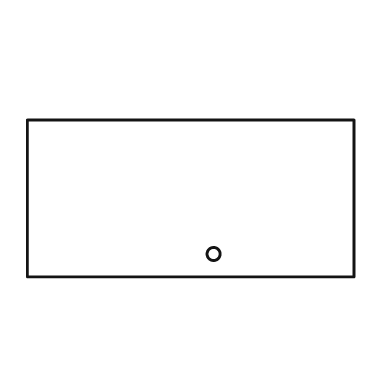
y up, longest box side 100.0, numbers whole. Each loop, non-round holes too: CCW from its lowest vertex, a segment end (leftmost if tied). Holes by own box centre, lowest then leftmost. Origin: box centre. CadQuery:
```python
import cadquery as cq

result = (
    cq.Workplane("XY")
    .moveTo(-50.0, -24.0)
    .lineTo(50.0, -24.0)
    .lineTo(50.0, 24.0)
    .lineTo(-50.0, 24.0)
    .close()
    .moveTo(7.0, -17.0)
    .circle(2.0)
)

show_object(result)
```